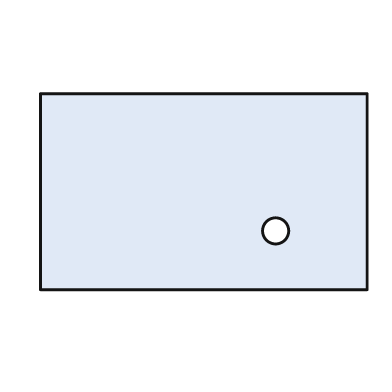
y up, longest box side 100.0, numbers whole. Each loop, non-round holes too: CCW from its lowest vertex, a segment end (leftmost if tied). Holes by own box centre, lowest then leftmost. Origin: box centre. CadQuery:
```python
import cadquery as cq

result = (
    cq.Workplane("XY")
    .moveTo(-50.0, -30.0)
    .lineTo(50.0, -30.0)
    .lineTo(50.0, 30.0)
    .lineTo(-50.0, 30.0)
    .close()
    .moveTo(22.0, -12.0)
    .circle(4.0)
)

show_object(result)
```